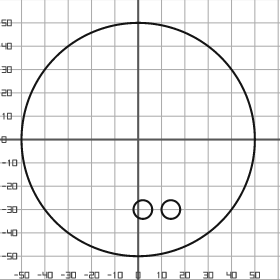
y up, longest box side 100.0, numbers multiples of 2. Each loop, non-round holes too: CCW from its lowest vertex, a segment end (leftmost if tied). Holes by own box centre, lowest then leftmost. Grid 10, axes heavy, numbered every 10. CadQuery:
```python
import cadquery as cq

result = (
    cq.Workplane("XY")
    .moveTo(0.0, 0.0)
    .circle(50.0)
    .moveTo(2.0, -30.0)
    .circle(4.0)
    .moveTo(14.0, -30.0)
    .circle(4.0)
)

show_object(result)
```